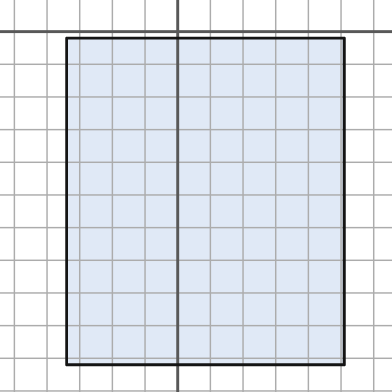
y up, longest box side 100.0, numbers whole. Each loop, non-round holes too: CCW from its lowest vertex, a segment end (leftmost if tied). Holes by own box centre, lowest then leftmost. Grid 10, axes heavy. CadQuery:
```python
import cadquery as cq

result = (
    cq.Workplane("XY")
    .moveTo(-34.0, -102.0)
    .lineTo(51.0, -102.0)
    .lineTo(51.0, -2.0)
    .lineTo(-34.0, -2.0)
    .close()
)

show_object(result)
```